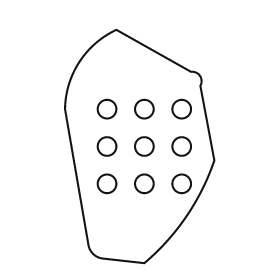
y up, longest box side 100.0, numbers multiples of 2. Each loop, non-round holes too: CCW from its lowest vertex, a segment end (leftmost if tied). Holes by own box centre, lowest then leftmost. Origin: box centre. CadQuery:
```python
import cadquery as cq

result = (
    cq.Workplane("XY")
    .moveTo(2.0, -50.0)
    .threePointArc((20.0, -30.0), (32.0, -6.0))
    .lineTo(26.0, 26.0)
    .threePointArc((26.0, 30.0), (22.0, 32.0))
    .lineTo(-10.0, 50.0)
    .threePointArc((-26.0, 36.0), (-32.0, 16.0))
    .lineTo(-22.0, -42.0)
    .threePointArc((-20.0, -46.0), (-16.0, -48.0))
    .close()
    .moveTo(-14.0, -16.0)
    .circle(4.0)
    .moveTo(2.0, -16.0)
    .circle(4.0)
    .moveTo(18.0, -16.0)
    .circle(4.0)
    .moveTo(-14.0, 0.0)
    .circle(4.0)
    .moveTo(2.0, 0.0)
    .circle(4.0)
    .moveTo(18.0, 0.0)
    .circle(4.0)
    .moveTo(-14.0, 16.0)
    .circle(4.0)
    .moveTo(2.0, 16.0)
    .circle(4.0)
    .moveTo(18.0, 16.0)
    .circle(4.0)
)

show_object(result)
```